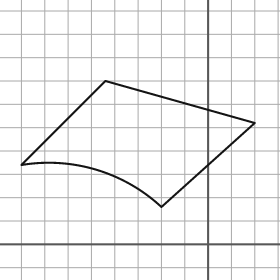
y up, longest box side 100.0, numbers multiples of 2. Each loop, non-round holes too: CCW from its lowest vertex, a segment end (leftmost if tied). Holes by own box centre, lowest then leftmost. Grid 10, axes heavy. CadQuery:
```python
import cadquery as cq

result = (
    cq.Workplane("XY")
    .moveTo(-20.0, 16.0)
    .lineTo(20.0, 52.0)
    .lineTo(-44.0, 70.0)
    .lineTo(-80.0, 34.0)
    .threePointArc((-48.0, 32.0), (-20.0, 16.0))
    .close()
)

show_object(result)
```